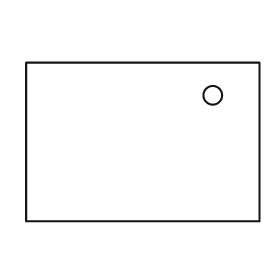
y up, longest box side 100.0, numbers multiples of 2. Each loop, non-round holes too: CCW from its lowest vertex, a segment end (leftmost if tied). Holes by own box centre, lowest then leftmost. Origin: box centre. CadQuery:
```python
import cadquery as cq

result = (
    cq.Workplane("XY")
    .moveTo(-50.0, -34.0)
    .lineTo(50.0, -34.0)
    .lineTo(50.0, 34.0)
    .lineTo(-50.0, 34.0)
    .close()
    .moveTo(30.0, 20.0)
    .circle(4.0)
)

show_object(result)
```